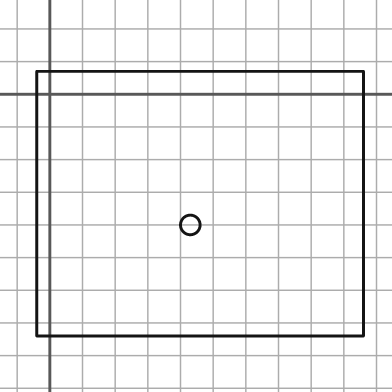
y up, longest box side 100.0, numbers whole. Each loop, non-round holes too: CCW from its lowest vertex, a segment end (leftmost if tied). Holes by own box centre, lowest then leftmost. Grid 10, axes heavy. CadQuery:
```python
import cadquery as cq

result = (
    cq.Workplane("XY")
    .moveTo(-4.0, -74.0)
    .lineTo(96.0, -74.0)
    .lineTo(96.0, 7.0)
    .lineTo(-4.0, 7.0)
    .close()
    .moveTo(43.0, -40.0)
    .circle(3.0)
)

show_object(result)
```